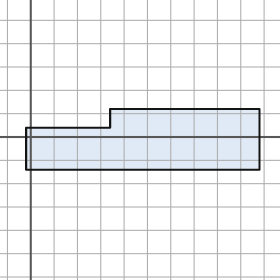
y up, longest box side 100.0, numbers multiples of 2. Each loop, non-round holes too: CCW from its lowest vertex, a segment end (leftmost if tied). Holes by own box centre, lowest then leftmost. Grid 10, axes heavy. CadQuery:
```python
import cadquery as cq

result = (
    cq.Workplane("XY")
    .moveTo(-2.0, -14.0)
    .lineTo(98.0, -14.0)
    .lineTo(98.0, 12.0)
    .lineTo(34.0, 12.0)
    .lineTo(34.0, 4.0)
    .lineTo(-2.0, 4.0)
    .close()
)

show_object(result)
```